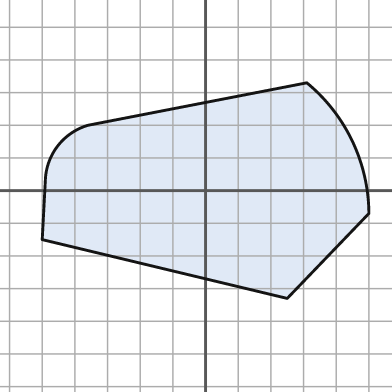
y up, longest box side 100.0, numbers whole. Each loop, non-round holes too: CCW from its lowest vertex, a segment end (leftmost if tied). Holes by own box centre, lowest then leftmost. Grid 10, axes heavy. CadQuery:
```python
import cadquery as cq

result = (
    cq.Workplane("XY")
    .moveTo(25.0, -33.0)
    .lineTo(50.0, -7.0)
    .threePointArc((45.0, 15.0), (31.0, 33.0))
    .lineTo(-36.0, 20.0)
    .threePointArc((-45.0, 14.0), (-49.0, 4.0))
    .lineTo(-50.0, -15.0)
    .close()
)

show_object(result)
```